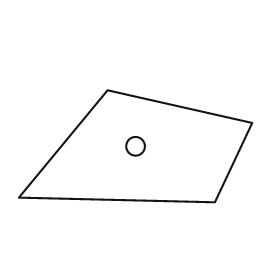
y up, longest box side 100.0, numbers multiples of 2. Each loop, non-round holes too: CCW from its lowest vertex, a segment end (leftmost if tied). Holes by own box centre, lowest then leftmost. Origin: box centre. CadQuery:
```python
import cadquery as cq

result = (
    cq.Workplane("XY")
    .moveTo(34.0, -24.0)
    .lineTo(50.0, 10.0)
    .lineTo(-12.0, 24.0)
    .lineTo(-50.0, -22.0)
    .close()
    .moveTo(0.0, 0.0)
    .circle(4.0)
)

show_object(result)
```